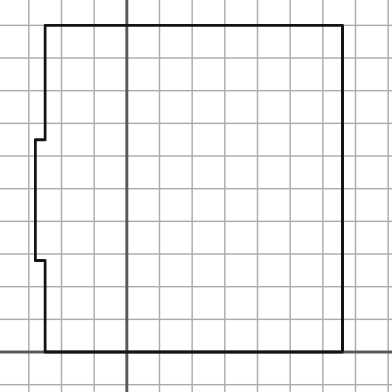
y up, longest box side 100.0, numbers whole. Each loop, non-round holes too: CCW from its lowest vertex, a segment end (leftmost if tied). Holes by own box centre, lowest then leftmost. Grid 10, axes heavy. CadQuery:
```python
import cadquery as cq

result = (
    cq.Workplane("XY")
    .moveTo(-25.0, 0.0)
    .lineTo(66.0, 0.0)
    .lineTo(66.0, 100.0)
    .lineTo(-25.0, 100.0)
    .lineTo(-25.0, 65.0)
    .lineTo(-28.0, 65.0)
    .lineTo(-28.0, 28.0)
    .lineTo(-25.0, 28.0)
    .close()
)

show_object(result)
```